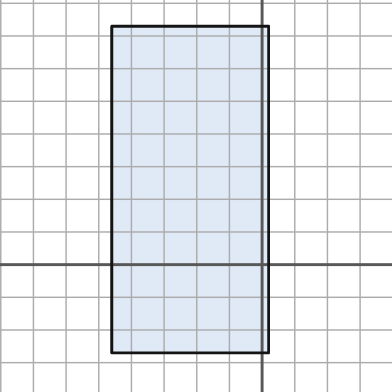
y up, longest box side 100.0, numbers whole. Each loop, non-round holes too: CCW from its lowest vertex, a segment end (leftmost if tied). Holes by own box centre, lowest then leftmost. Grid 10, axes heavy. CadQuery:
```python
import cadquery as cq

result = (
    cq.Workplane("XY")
    .moveTo(-46.0, -27.0)
    .lineTo(2.0, -27.0)
    .lineTo(2.0, 73.0)
    .lineTo(-46.0, 73.0)
    .close()
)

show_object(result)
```